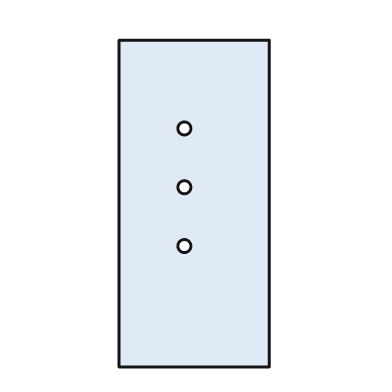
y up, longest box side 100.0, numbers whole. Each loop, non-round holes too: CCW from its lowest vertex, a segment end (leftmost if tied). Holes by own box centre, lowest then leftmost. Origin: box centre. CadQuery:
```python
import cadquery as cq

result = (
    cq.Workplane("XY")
    .moveTo(-23.0, -50.0)
    .lineTo(23.0, -50.0)
    .lineTo(23.0, 50.0)
    .lineTo(-23.0, 50.0)
    .close()
    .moveTo(-3.0, -13.0)
    .circle(2.0)
    .moveTo(-3.0, 5.0)
    .circle(2.0)
    .moveTo(-3.0, 23.0)
    .circle(2.0)
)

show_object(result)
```